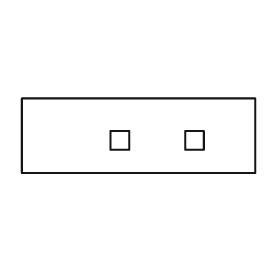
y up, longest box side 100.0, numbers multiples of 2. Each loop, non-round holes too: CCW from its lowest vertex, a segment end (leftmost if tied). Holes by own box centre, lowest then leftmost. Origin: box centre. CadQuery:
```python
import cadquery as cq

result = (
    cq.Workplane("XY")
    .moveTo(-50.0, -16.0)
    .lineTo(50.0, -16.0)
    .lineTo(50.0, 16.0)
    .lineTo(-50.0, 16.0)
    .close()
    .moveTo(-12.0, -6.0)
    .lineTo(-4.0, -6.0)
    .lineTo(-4.0, 2.0)
    .lineTo(-12.0, 2.0)
    .close()
    .moveTo(20.0, -6.0)
    .lineTo(28.0, -6.0)
    .lineTo(28.0, 2.0)
    .lineTo(20.0, 2.0)
    .close()
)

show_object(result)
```